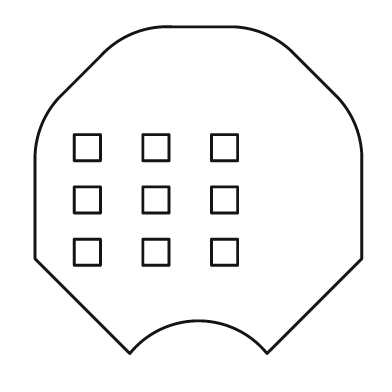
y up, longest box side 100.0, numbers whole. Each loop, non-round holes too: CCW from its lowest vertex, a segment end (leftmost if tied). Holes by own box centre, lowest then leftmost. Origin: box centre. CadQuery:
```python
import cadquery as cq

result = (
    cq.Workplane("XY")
    .moveTo(-21.0, -50.0)
    .threePointArc((0.0, -40.0), (21.0, -50.0))
    .lineTo(50.0, -21.0)
    .lineTo(50.0, 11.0)
    .threePointArc((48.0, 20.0), (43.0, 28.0))
    .lineTo(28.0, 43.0)
    .threePointArc((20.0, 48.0), (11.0, 50.0))
    .lineTo(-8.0, 50.0)
    .threePointArc((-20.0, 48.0), (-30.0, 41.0))
    .lineTo(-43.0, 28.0)
    .threePointArc((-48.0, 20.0), (-50.0, 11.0))
    .lineTo(-50.0, -21.0)
    .close()
    .moveTo(-38.0, -23.0)
    .lineTo(-30.0, -23.0)
    .lineTo(-30.0, -15.0)
    .lineTo(-38.0, -15.0)
    .close()
    .moveTo(-17.0, -23.0)
    .lineTo(-9.0, -23.0)
    .lineTo(-9.0, -15.0)
    .lineTo(-17.0, -15.0)
    .close()
    .moveTo(4.0, -23.0)
    .lineTo(12.0, -23.0)
    .lineTo(12.0, -15.0)
    .lineTo(4.0, -15.0)
    .close()
    .moveTo(-38.0, -7.0)
    .lineTo(-30.0, -7.0)
    .lineTo(-30.0, 1.0)
    .lineTo(-38.0, 1.0)
    .close()
    .moveTo(-17.0, -7.0)
    .lineTo(-9.0, -7.0)
    .lineTo(-9.0, 1.0)
    .lineTo(-17.0, 1.0)
    .close()
    .moveTo(4.0, -7.0)
    .lineTo(12.0, -7.0)
    .lineTo(12.0, 1.0)
    .lineTo(4.0, 1.0)
    .close()
    .moveTo(-38.0, 9.0)
    .lineTo(-30.0, 9.0)
    .lineTo(-30.0, 17.0)
    .lineTo(-38.0, 17.0)
    .close()
    .moveTo(-17.0, 9.0)
    .lineTo(-9.0, 9.0)
    .lineTo(-9.0, 17.0)
    .lineTo(-17.0, 17.0)
    .close()
    .moveTo(4.0, 9.0)
    .lineTo(12.0, 9.0)
    .lineTo(12.0, 17.0)
    .lineTo(4.0, 17.0)
    .close()
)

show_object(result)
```